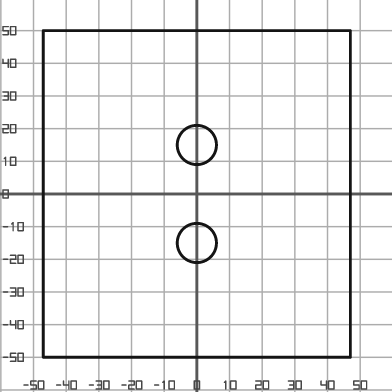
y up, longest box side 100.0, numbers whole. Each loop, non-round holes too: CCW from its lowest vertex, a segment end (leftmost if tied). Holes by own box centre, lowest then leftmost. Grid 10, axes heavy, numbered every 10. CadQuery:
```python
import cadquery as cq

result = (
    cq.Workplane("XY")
    .moveTo(-47.0, -50.0)
    .lineTo(47.0, -50.0)
    .lineTo(47.0, 50.0)
    .lineTo(-47.0, 50.0)
    .close()
    .moveTo(0.0, -15.0)
    .circle(6.0)
    .moveTo(0.0, 15.0)
    .circle(6.0)
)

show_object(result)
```